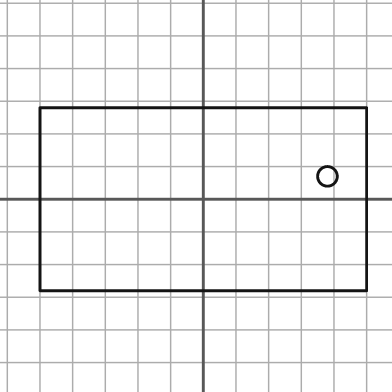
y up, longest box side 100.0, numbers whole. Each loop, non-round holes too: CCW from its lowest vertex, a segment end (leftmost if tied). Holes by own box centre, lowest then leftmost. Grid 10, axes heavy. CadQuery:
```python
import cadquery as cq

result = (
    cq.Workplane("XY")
    .moveTo(-50.0, -28.0)
    .lineTo(50.0, -28.0)
    .lineTo(50.0, 28.0)
    .lineTo(-50.0, 28.0)
    .close()
    .moveTo(38.0, 7.0)
    .circle(3.0)
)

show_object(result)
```